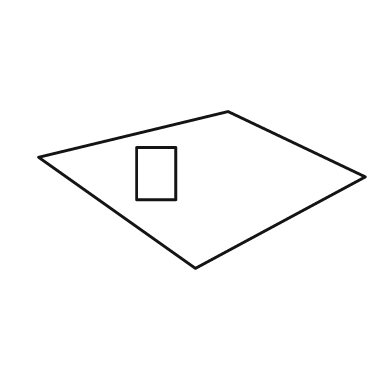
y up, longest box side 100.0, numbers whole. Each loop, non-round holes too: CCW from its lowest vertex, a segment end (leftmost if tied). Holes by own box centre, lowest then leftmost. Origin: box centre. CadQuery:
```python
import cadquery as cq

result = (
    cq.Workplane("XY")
    .moveTo(-2.0, -24.0)
    .lineTo(50.0, 4.0)
    .lineTo(8.0, 24.0)
    .lineTo(-50.0, 10.0)
    .close()
    .moveTo(-20.0, -3.0)
    .lineTo(-8.0, -3.0)
    .lineTo(-8.0, 13.0)
    .lineTo(-20.0, 13.0)
    .close()
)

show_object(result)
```